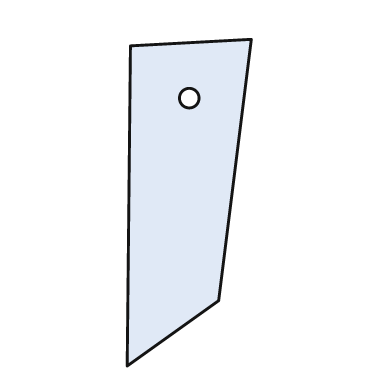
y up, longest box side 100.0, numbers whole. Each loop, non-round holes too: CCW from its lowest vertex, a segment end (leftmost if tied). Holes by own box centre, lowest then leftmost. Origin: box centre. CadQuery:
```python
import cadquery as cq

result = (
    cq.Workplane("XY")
    .moveTo(-19.0, -50.0)
    .lineTo(9.0, -30.0)
    .lineTo(19.0, 50.0)
    .lineTo(-18.0, 48.0)
    .close()
    .moveTo(0.0, 32.0)
    .circle(3.0)
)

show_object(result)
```